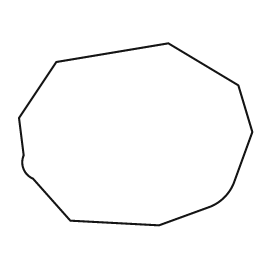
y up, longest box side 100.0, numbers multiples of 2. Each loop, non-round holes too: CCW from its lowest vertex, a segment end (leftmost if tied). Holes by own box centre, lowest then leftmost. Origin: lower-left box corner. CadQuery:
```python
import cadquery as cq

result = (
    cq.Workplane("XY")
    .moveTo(60.0, 0.0)
    .lineTo(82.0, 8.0)
    .threePointArc((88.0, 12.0), (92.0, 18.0))
    .lineTo(100.0, 40.0)
    .lineTo(94.0, 60.0)
    .lineTo(64.0, 78.0)
    .lineTo(16.0, 70.0)
    .lineTo(0.0, 46.0)
    .lineTo(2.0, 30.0)
    .threePointArc((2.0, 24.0), (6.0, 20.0))
    .lineTo(22.0, 2.0)
    .close()
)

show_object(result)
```